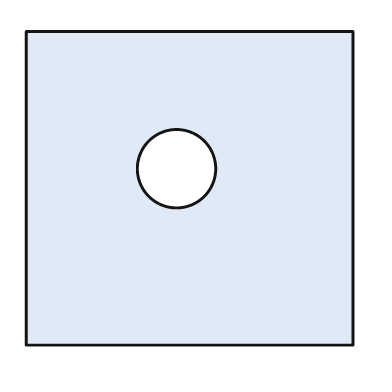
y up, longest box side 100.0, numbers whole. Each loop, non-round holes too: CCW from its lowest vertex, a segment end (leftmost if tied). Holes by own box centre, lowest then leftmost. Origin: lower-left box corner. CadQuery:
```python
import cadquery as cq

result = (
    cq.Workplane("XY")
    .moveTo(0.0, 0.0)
    .lineTo(100.0, 0.0)
    .lineTo(100.0, 96.0)
    .lineTo(0.0, 96.0)
    .close()
    .moveTo(46.0, 54.0)
    .circle(12.0)
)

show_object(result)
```